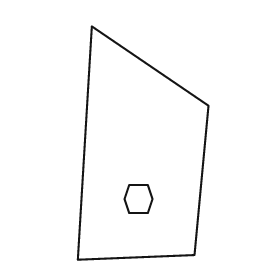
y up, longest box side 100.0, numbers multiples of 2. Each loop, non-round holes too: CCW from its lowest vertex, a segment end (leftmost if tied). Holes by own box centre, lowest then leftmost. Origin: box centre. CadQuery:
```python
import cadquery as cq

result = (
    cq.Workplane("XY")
    .moveTo(-28.0, -50.0)
    .lineTo(22.0, -48.0)
    .lineTo(28.0, 16.0)
    .lineTo(-22.0, 50.0)
    .close()
    .moveTo(-6.0, -30.0)
    .lineTo(2.0, -30.0)
    .lineTo(4.0, -24.0)
    .lineTo(2.0, -18.0)
    .lineTo(-6.0, -18.0)
    .lineTo(-8.0, -24.0)
    .close()
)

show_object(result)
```